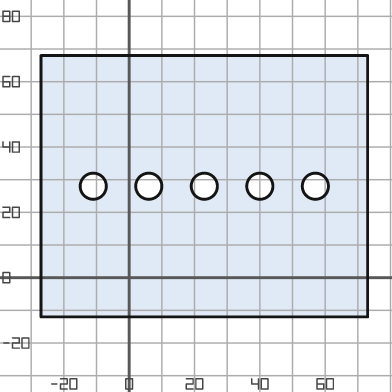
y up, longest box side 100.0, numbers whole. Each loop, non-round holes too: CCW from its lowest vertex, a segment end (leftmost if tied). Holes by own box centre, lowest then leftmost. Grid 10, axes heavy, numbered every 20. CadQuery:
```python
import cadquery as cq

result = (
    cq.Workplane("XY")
    .moveTo(-27.0, -12.0)
    .lineTo(73.0, -12.0)
    .lineTo(73.0, 68.0)
    .lineTo(-27.0, 68.0)
    .close()
    .moveTo(-11.0, 28.0)
    .circle(4.0)
    .moveTo(6.0, 28.0)
    .circle(4.0)
    .moveTo(23.0, 28.0)
    .circle(4.0)
    .moveTo(40.0, 28.0)
    .circle(4.0)
    .moveTo(57.0, 28.0)
    .circle(4.0)
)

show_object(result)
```